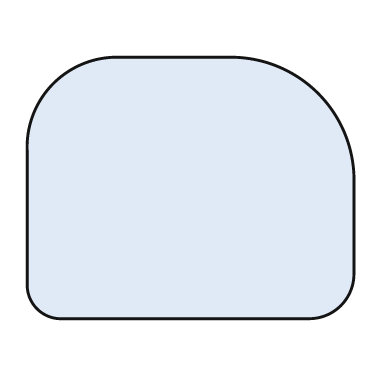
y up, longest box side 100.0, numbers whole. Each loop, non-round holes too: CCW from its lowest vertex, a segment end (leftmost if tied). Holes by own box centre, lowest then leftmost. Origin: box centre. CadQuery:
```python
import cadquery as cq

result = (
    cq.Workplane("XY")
    .moveTo(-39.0, -40.0)
    .lineTo(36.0, -40.0)
    .threePointArc((46.0, -36.0), (50.0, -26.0))
    .lineTo(50.0, 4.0)
    .threePointArc((39.0, 29.0), (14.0, 40.0))
    .lineTo(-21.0, 40.0)
    .threePointArc((-42.0, 32.0), (-50.0, 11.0))
    .lineTo(-50.0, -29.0)
    .threePointArc((-47.0, -37.0), (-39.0, -40.0))
    .close()
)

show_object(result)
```